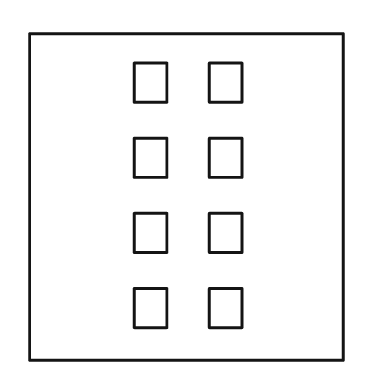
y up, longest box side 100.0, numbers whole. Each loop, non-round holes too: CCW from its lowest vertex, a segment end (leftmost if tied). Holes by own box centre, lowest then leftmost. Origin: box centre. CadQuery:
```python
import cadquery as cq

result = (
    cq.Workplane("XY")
    .moveTo(-48.0, -50.0)
    .lineTo(48.0, -50.0)
    .lineTo(48.0, 50.0)
    .lineTo(-48.0, 50.0)
    .close()
    .moveTo(-16.0, -40.0)
    .lineTo(-6.0, -40.0)
    .lineTo(-6.0, -28.0)
    .lineTo(-16.0, -28.0)
    .close()
    .moveTo(7.0, -40.0)
    .lineTo(17.0, -40.0)
    .lineTo(17.0, -28.0)
    .lineTo(7.0, -28.0)
    .close()
    .moveTo(-16.0, -17.0)
    .lineTo(-6.0, -17.0)
    .lineTo(-6.0, -5.0)
    .lineTo(-16.0, -5.0)
    .close()
    .moveTo(7.0, -17.0)
    .lineTo(17.0, -17.0)
    .lineTo(17.0, -5.0)
    .lineTo(7.0, -5.0)
    .close()
    .moveTo(-16.0, 6.0)
    .lineTo(-6.0, 6.0)
    .lineTo(-6.0, 18.0)
    .lineTo(-16.0, 18.0)
    .close()
    .moveTo(7.0, 6.0)
    .lineTo(17.0, 6.0)
    .lineTo(17.0, 18.0)
    .lineTo(7.0, 18.0)
    .close()
    .moveTo(-16.0, 29.0)
    .lineTo(-6.0, 29.0)
    .lineTo(-6.0, 41.0)
    .lineTo(-16.0, 41.0)
    .close()
    .moveTo(7.0, 29.0)
    .lineTo(17.0, 29.0)
    .lineTo(17.0, 41.0)
    .lineTo(7.0, 41.0)
    .close()
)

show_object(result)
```